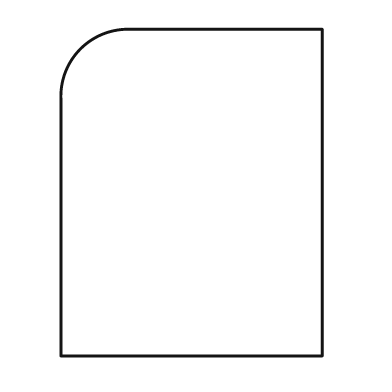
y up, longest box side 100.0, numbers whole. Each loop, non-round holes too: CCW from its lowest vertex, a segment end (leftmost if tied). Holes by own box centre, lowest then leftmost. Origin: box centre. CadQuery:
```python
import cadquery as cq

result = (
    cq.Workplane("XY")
    .moveTo(-40.0, -50.0)
    .lineTo(40.0, -50.0)
    .lineTo(40.0, 50.0)
    .lineTo(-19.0, 50.0)
    .threePointArc((-34.0, 44.0), (-40.0, 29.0))
    .close()
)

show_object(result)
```